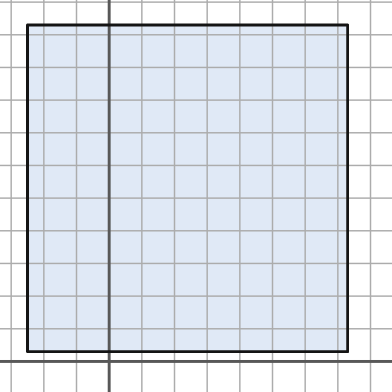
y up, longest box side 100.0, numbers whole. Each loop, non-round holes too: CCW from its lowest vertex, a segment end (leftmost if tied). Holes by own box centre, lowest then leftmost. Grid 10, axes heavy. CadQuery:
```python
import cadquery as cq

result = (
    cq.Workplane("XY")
    .moveTo(-25.0, 3.0)
    .lineTo(73.0, 3.0)
    .lineTo(73.0, 103.0)
    .lineTo(-25.0, 103.0)
    .close()
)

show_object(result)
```